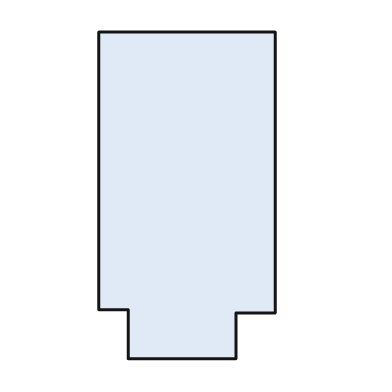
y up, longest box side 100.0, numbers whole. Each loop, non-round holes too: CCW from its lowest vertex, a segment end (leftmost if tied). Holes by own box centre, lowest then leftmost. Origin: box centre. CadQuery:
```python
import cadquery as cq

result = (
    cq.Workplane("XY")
    .moveTo(-18.0, -50.0)
    .lineTo(15.0, -50.0)
    .lineTo(15.0, -36.0)
    .lineTo(27.0, -36.0)
    .lineTo(27.0, 50.0)
    .lineTo(-27.0, 50.0)
    .lineTo(-27.0, -35.0)
    .lineTo(-18.0, -35.0)
    .close()
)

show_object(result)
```